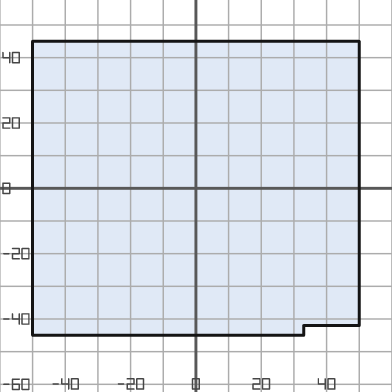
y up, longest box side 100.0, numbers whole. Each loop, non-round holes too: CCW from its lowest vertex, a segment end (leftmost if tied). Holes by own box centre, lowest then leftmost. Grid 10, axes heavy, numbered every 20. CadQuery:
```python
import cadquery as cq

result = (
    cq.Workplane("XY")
    .moveTo(-50.0, -45.0)
    .lineTo(33.0, -45.0)
    .lineTo(33.0, -42.0)
    .lineTo(50.0, -42.0)
    .lineTo(50.0, 45.0)
    .lineTo(-50.0, 45.0)
    .close()
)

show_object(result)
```